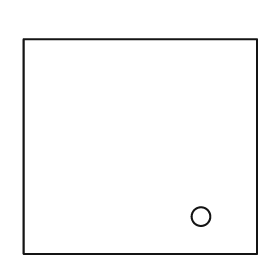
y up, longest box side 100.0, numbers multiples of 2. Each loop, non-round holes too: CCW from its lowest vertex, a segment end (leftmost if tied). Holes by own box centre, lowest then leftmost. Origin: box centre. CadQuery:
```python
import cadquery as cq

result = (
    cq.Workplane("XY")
    .moveTo(-50.0, -46.0)
    .lineTo(50.0, -46.0)
    .lineTo(50.0, 46.0)
    .lineTo(-50.0, 46.0)
    .close()
    .moveTo(26.0, -30.0)
    .circle(4.0)
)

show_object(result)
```